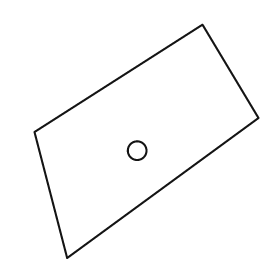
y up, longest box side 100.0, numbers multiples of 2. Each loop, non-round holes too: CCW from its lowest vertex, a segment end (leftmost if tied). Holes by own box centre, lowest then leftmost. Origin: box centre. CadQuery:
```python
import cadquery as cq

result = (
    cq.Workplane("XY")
    .moveTo(-34.0, -50.0)
    .lineTo(48.0, 10.0)
    .lineTo(24.0, 50.0)
    .lineTo(-48.0, 4.0)
    .close()
    .moveTo(-4.0, -4.0)
    .circle(4.0)
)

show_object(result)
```